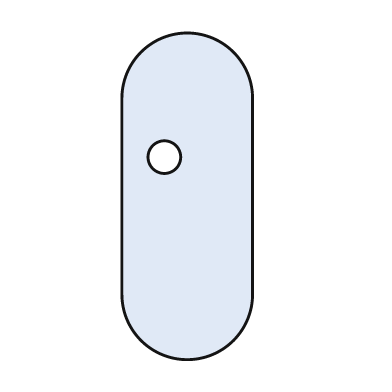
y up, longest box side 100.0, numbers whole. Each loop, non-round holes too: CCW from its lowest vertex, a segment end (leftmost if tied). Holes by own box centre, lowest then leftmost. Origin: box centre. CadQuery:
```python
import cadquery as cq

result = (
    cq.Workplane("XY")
    .moveTo(-20.0, -30.0)
    .threePointArc((0.0, -50.0), (20.0, -30.0))
    .lineTo(20.0, 30.0)
    .threePointArc((0.0, 50.0), (-20.0, 30.0))
    .close()
    .moveTo(-7.0, 12.0)
    .circle(5.0)
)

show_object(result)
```